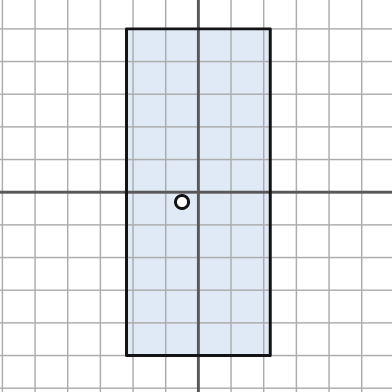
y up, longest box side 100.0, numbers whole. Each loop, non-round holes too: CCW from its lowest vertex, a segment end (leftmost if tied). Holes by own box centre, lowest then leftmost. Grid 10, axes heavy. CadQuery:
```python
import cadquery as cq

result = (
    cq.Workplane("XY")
    .moveTo(-22.0, -50.0)
    .lineTo(22.0, -50.0)
    .lineTo(22.0, 50.0)
    .lineTo(-22.0, 50.0)
    .close()
    .moveTo(-5.0, -3.0)
    .circle(2.0)
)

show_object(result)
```